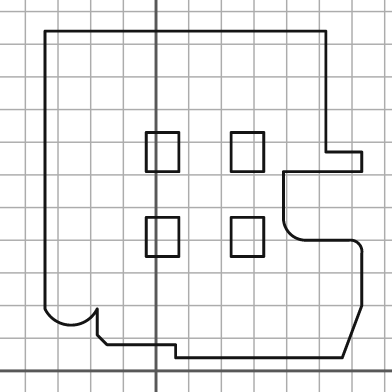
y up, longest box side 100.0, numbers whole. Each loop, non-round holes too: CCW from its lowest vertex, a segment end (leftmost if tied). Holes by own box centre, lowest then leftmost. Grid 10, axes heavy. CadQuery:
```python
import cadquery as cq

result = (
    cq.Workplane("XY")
    .moveTo(6.0, 4.0)
    .lineTo(57.0, 4.0)
    .lineTo(63.0, 20.0)
    .lineTo(63.0, 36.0)
    .threePointArc((62.0, 39.0), (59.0, 40.0))
    .lineTo(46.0, 40.0)
    .threePointArc((41.0, 42.0), (39.0, 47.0))
    .lineTo(39.0, 61.0)
    .lineTo(63.0, 61.0)
    .lineTo(63.0, 67.0)
    .lineTo(52.0, 67.0)
    .lineTo(52.0, 104.0)
    .lineTo(-34.0, 104.0)
    .lineTo(-34.0, 19.0)
    .threePointArc((-26.0, 14.0), (-18.0, 19.0))
    .lineTo(-18.0, 11.0)
    .lineTo(-15.0, 8.0)
    .lineTo(6.0, 8.0)
    .close()
    .moveTo(-3.0, 35.0)
    .lineTo(7.0, 35.0)
    .lineTo(7.0, 47.0)
    .lineTo(-3.0, 47.0)
    .close()
    .moveTo(23.0, 35.0)
    .lineTo(33.0, 35.0)
    .lineTo(33.0, 47.0)
    .lineTo(23.0, 47.0)
    .close()
    .moveTo(-3.0, 61.0)
    .lineTo(7.0, 61.0)
    .lineTo(7.0, 73.0)
    .lineTo(-3.0, 73.0)
    .close()
    .moveTo(23.0, 61.0)
    .lineTo(33.0, 61.0)
    .lineTo(33.0, 73.0)
    .lineTo(23.0, 73.0)
    .close()
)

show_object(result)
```